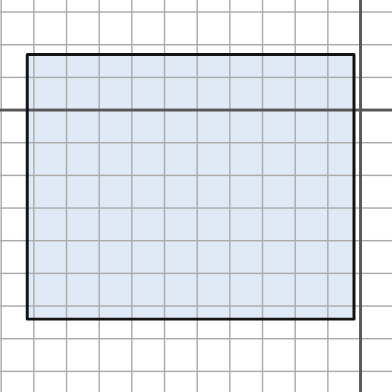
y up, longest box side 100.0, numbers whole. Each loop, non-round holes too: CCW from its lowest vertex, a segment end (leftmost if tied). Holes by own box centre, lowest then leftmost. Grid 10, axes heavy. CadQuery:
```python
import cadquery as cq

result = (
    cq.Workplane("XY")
    .moveTo(-102.0, -64.0)
    .lineTo(-2.0, -64.0)
    .lineTo(-2.0, 17.0)
    .lineTo(-102.0, 17.0)
    .close()
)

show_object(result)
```